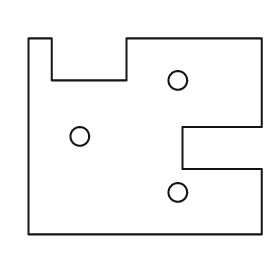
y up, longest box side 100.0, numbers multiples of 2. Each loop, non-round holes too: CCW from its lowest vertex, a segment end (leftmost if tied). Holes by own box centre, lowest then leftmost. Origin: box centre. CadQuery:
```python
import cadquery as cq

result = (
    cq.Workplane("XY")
    .moveTo(-50.0, -42.0)
    .lineTo(50.0, -42.0)
    .lineTo(50.0, -14.0)
    .lineTo(16.0, -14.0)
    .lineTo(16.0, 4.0)
    .lineTo(50.0, 4.0)
    .lineTo(50.0, 42.0)
    .lineTo(-8.0, 42.0)
    .lineTo(-8.0, 24.0)
    .lineTo(-40.0, 24.0)
    .lineTo(-40.0, 42.0)
    .lineTo(-50.0, 42.0)
    .close()
    .moveTo(14.0, -24.0)
    .circle(4.0)
    .moveTo(-28.0, 0.0)
    .circle(4.0)
    .moveTo(14.0, 24.0)
    .circle(4.0)
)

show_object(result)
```